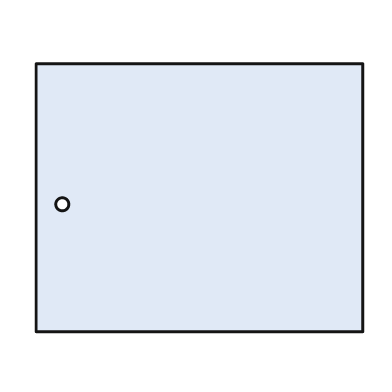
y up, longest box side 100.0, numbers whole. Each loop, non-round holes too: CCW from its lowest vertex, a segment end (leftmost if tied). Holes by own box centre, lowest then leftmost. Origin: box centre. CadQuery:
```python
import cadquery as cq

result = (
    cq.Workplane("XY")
    .moveTo(-50.0, -41.0)
    .lineTo(50.0, -41.0)
    .lineTo(50.0, 41.0)
    .lineTo(-50.0, 41.0)
    .close()
    .moveTo(-42.0, -2.0)
    .circle(2.0)
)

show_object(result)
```